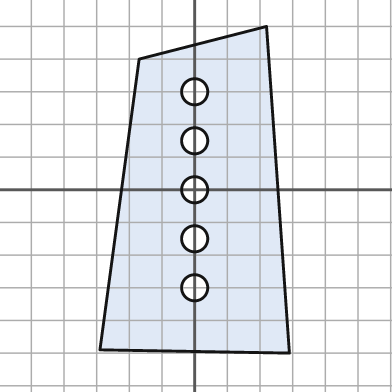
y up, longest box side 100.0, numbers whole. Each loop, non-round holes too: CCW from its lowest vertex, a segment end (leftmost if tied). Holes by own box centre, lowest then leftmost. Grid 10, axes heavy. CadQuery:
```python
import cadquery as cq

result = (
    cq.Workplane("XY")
    .moveTo(29.0, -50.0)
    .lineTo(22.0, 50.0)
    .lineTo(-17.0, 40.0)
    .lineTo(-29.0, -49.0)
    .close()
    .moveTo(0.0, -30.0)
    .circle(4.0)
    .moveTo(0.0, -15.0)
    .circle(4.0)
    .moveTo(0.0, 0.0)
    .circle(4.0)
    .moveTo(0.0, 15.0)
    .circle(4.0)
    .moveTo(0.0, 30.0)
    .circle(4.0)
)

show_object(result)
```